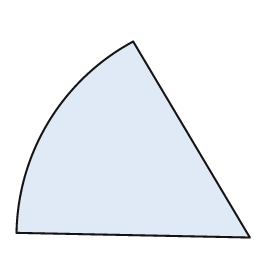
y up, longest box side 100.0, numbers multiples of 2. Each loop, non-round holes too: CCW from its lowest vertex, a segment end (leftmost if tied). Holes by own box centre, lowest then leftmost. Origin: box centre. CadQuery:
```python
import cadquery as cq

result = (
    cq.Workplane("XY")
    .moveTo(50.0, -42.0)
    .lineTo(0.0, 42.0)
    .threePointArc((-36.0, 8.0), (-50.0, -40.0))
    .close()
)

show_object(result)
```